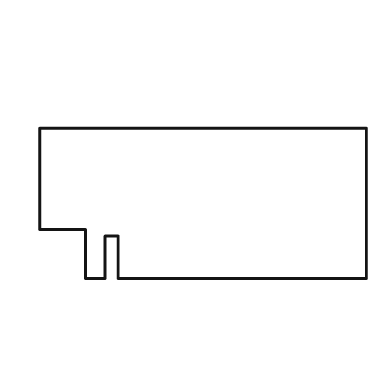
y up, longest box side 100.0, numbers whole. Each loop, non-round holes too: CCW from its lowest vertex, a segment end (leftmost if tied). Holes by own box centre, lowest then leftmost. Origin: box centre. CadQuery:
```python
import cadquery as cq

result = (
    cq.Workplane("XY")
    .moveTo(-36.0, -23.0)
    .lineTo(-30.0, -23.0)
    .lineTo(-30.0, -10.0)
    .lineTo(-26.0, -10.0)
    .lineTo(-26.0, -23.0)
    .lineTo(50.0, -23.0)
    .lineTo(50.0, 23.0)
    .lineTo(-50.0, 23.0)
    .lineTo(-50.0, -8.0)
    .lineTo(-36.0, -8.0)
    .close()
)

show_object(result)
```